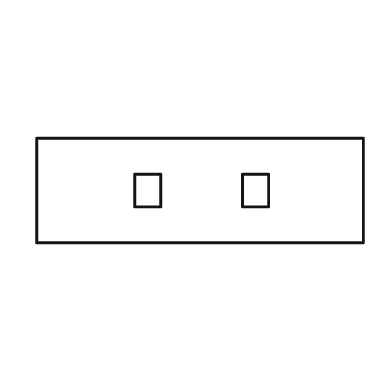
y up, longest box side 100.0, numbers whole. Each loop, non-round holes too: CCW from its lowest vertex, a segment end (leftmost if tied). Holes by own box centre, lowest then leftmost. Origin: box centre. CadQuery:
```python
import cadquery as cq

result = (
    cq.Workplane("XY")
    .moveTo(-50.0, -16.0)
    .lineTo(50.0, -16.0)
    .lineTo(50.0, 16.0)
    .lineTo(-50.0, 16.0)
    .close()
    .moveTo(-20.0, -5.0)
    .lineTo(-12.0, -5.0)
    .lineTo(-12.0, 5.0)
    .lineTo(-20.0, 5.0)
    .close()
    .moveTo(13.0, -5.0)
    .lineTo(21.0, -5.0)
    .lineTo(21.0, 5.0)
    .lineTo(13.0, 5.0)
    .close()
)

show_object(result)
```